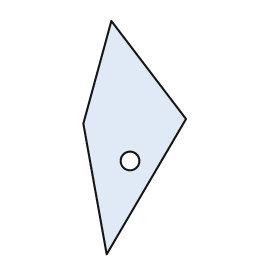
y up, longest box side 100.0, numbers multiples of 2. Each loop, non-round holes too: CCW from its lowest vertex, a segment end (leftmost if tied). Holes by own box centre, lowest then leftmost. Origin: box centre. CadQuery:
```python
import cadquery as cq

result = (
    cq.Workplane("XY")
    .moveTo(-12.0, -50.0)
    .lineTo(22.0, 8.0)
    .lineTo(-10.0, 50.0)
    .lineTo(-22.0, 6.0)
    .close()
    .moveTo(-2.0, -10.0)
    .circle(4.0)
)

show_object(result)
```